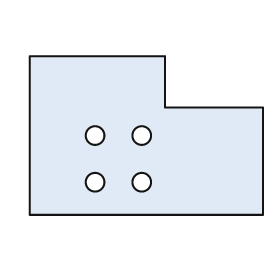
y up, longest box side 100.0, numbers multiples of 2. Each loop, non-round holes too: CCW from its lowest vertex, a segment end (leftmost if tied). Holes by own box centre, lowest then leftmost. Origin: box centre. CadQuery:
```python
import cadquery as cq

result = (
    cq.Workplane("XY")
    .moveTo(-50.0, -34.0)
    .lineTo(50.0, -34.0)
    .lineTo(50.0, 12.0)
    .lineTo(8.0, 12.0)
    .lineTo(8.0, 34.0)
    .lineTo(-50.0, 34.0)
    .close()
    .moveTo(-22.0, -20.0)
    .circle(4.0)
    .moveTo(-2.0, -20.0)
    .circle(4.0)
    .moveTo(-22.0, 0.0)
    .circle(4.0)
    .moveTo(-2.0, 0.0)
    .circle(4.0)
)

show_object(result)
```